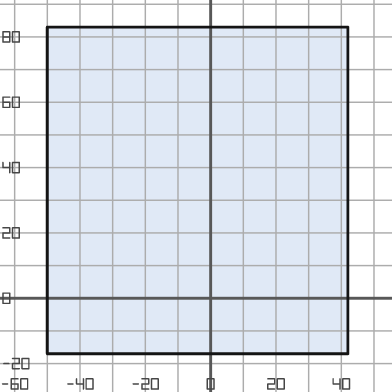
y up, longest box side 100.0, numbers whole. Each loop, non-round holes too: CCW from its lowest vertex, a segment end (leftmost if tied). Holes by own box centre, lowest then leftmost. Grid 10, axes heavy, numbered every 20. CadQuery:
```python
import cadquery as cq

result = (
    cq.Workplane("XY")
    .moveTo(-50.0, -17.0)
    .lineTo(42.0, -17.0)
    .lineTo(42.0, 83.0)
    .lineTo(-50.0, 83.0)
    .close()
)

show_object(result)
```